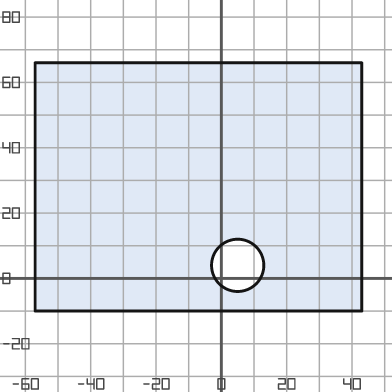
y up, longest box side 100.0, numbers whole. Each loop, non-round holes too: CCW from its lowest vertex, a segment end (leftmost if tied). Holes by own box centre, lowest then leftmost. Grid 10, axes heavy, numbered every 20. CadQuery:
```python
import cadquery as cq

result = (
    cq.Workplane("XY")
    .moveTo(-57.0, -10.0)
    .lineTo(43.0, -10.0)
    .lineTo(43.0, 66.0)
    .lineTo(-57.0, 66.0)
    .close()
    .moveTo(5.0, 4.0)
    .circle(8.0)
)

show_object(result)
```